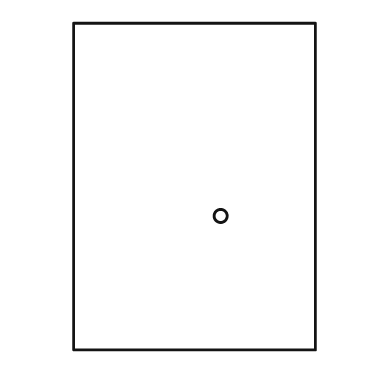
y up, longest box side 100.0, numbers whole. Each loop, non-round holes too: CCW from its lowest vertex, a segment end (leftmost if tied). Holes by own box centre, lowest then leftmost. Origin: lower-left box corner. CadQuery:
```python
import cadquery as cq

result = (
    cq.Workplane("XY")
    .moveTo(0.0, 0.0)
    .lineTo(74.0, 0.0)
    .lineTo(74.0, 100.0)
    .lineTo(0.0, 100.0)
    .close()
    .moveTo(45.0, 41.0)
    .circle(2.0)
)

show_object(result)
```